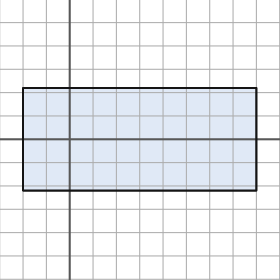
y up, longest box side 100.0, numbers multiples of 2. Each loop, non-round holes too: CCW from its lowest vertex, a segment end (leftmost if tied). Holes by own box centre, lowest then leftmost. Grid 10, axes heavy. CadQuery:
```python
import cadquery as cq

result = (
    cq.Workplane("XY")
    .moveTo(-20.0, -22.0)
    .lineTo(80.0, -22.0)
    .lineTo(80.0, 22.0)
    .lineTo(-20.0, 22.0)
    .close()
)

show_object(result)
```